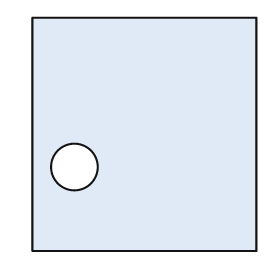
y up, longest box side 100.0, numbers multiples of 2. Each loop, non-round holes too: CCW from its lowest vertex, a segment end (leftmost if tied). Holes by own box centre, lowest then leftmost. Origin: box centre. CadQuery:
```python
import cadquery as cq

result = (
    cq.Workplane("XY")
    .moveTo(-48.0, -50.0)
    .lineTo(48.0, -50.0)
    .lineTo(48.0, 50.0)
    .lineTo(-48.0, 50.0)
    .close()
    .moveTo(-30.0, -14.0)
    .circle(10.0)
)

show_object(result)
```